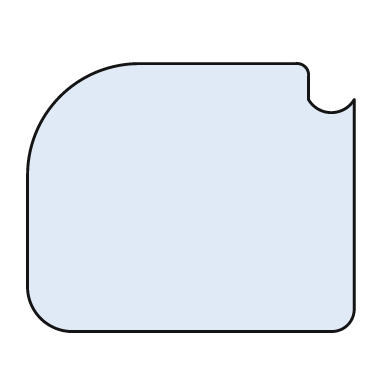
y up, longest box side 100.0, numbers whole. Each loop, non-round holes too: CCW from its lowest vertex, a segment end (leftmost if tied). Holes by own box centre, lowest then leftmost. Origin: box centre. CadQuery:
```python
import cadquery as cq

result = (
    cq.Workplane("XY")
    .moveTo(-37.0, -41.0)
    .lineTo(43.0, -41.0)
    .threePointArc((48.0, -39.0), (50.0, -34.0))
    .lineTo(50.0, 30.0)
    .threePointArc((43.0, 26.0), (36.0, 30.0))
    .lineTo(36.0, 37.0)
    .threePointArc((35.0, 40.0), (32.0, 41.0))
    .lineTo(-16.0, 41.0)
    .threePointArc((-40.0, 31.0), (-50.0, 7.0))
    .lineTo(-50.0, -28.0)
    .threePointArc((-46.0, -37.0), (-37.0, -41.0))
    .close()
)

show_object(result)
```